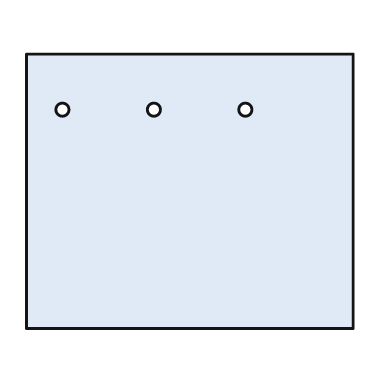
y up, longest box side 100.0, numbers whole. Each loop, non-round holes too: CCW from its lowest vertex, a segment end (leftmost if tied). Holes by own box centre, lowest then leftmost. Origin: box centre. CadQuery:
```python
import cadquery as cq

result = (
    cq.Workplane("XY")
    .moveTo(-50.0, -42.0)
    .lineTo(50.0, -42.0)
    .lineTo(50.0, 42.0)
    .lineTo(-50.0, 42.0)
    .close()
    .moveTo(-39.0, 25.0)
    .circle(2.0)
    .moveTo(-11.0, 25.0)
    .circle(2.0)
    .moveTo(17.0, 25.0)
    .circle(2.0)
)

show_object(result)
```